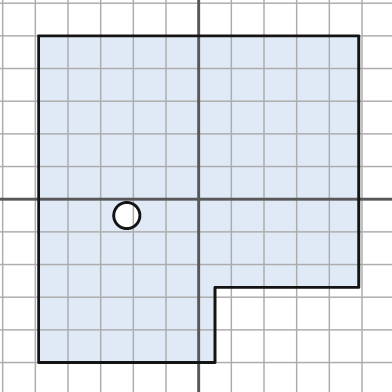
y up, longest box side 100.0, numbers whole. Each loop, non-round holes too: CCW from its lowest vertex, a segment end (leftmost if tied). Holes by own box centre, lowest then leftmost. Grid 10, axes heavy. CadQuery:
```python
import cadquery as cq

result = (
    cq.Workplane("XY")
    .moveTo(-49.0, -50.0)
    .lineTo(5.0, -50.0)
    .lineTo(5.0, -27.0)
    .lineTo(49.0, -27.0)
    .lineTo(49.0, 50.0)
    .lineTo(-49.0, 50.0)
    .close()
    .moveTo(-22.0, -5.0)
    .circle(4.0)
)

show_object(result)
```